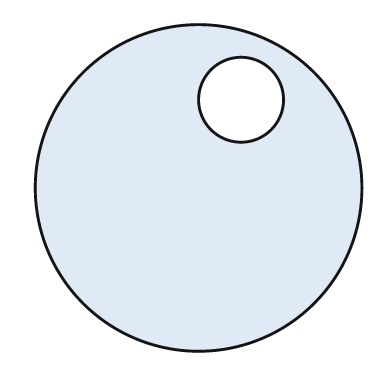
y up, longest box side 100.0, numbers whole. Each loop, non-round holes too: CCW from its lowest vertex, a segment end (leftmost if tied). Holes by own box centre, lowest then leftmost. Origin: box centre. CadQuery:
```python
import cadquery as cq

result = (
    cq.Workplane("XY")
    .moveTo(0.0, 0.0)
    .circle(50.0)
    .moveTo(13.0, 27.0)
    .circle(13.0)
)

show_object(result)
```